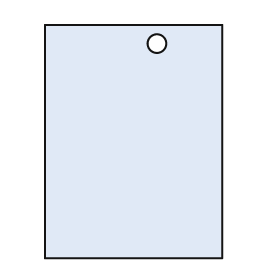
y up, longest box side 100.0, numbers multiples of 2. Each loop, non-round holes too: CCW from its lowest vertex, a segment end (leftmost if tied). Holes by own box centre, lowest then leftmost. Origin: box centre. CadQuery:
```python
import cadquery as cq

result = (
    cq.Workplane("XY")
    .moveTo(-38.0, -50.0)
    .lineTo(38.0, -50.0)
    .lineTo(38.0, 50.0)
    .lineTo(-38.0, 50.0)
    .close()
    .moveTo(10.0, 42.0)
    .circle(4.0)
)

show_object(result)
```